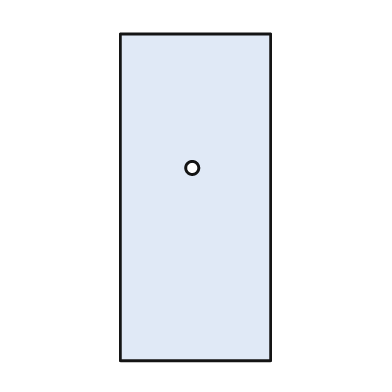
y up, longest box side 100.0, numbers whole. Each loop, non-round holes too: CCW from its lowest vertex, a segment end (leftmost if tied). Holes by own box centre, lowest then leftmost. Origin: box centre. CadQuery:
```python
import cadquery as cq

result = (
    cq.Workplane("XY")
    .moveTo(-23.0, -50.0)
    .lineTo(23.0, -50.0)
    .lineTo(23.0, 50.0)
    .lineTo(-23.0, 50.0)
    .close()
    .moveTo(-1.0, 9.0)
    .circle(2.0)
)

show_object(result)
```